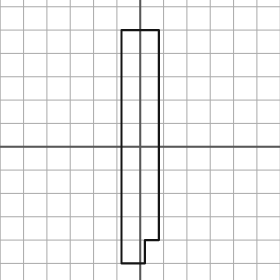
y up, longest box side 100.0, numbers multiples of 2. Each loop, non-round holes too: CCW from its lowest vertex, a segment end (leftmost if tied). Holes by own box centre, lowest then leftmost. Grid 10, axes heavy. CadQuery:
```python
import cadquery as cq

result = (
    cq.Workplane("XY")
    .moveTo(-8.0, -50.0)
    .lineTo(2.0, -50.0)
    .lineTo(2.0, -40.0)
    .lineTo(8.0, -40.0)
    .lineTo(8.0, 50.0)
    .lineTo(-8.0, 50.0)
    .close()
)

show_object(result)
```